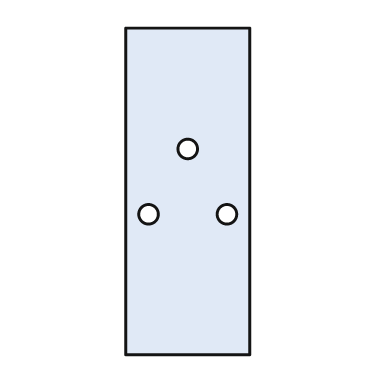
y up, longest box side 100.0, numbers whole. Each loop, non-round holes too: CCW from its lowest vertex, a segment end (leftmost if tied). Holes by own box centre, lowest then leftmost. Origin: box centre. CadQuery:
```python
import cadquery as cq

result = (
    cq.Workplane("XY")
    .moveTo(-19.0, -50.0)
    .lineTo(19.0, -50.0)
    .lineTo(19.0, 50.0)
    .lineTo(-19.0, 50.0)
    .close()
    .moveTo(-12.0, -7.0)
    .circle(3.0)
    .moveTo(12.0, -7.0)
    .circle(3.0)
    .moveTo(0.0, 13.0)
    .circle(3.0)
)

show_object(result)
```